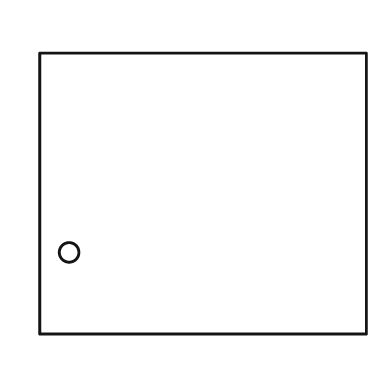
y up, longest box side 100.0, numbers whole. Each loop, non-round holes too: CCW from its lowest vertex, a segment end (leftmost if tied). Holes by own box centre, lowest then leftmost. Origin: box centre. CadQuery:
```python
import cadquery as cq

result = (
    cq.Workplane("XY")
    .moveTo(-50.0, -43.0)
    .lineTo(50.0, -43.0)
    .lineTo(50.0, 43.0)
    .lineTo(-50.0, 43.0)
    .close()
    .moveTo(-41.0, -18.0)
    .circle(3.0)
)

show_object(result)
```